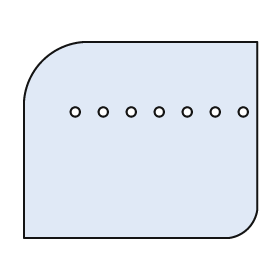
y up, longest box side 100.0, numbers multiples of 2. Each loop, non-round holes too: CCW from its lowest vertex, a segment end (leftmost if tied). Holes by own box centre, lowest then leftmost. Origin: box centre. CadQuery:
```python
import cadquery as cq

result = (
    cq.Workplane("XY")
    .moveTo(-50.0, -42.0)
    .lineTo(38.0, -42.0)
    .threePointArc((46.0, -38.0), (50.0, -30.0))
    .lineTo(50.0, 42.0)
    .lineTo(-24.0, 42.0)
    .threePointArc((-42.0, 34.0), (-50.0, 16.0))
    .close()
    .moveTo(-28.0, 12.0)
    .circle(2.0)
    .moveTo(-16.0, 12.0)
    .circle(2.0)
    .moveTo(-4.0, 12.0)
    .circle(2.0)
    .moveTo(8.0, 12.0)
    .circle(2.0)
    .moveTo(20.0, 12.0)
    .circle(2.0)
    .moveTo(32.0, 12.0)
    .circle(2.0)
    .moveTo(44.0, 12.0)
    .circle(2.0)
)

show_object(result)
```